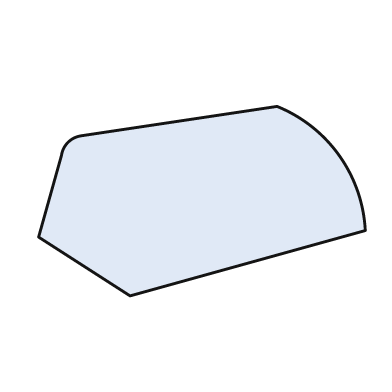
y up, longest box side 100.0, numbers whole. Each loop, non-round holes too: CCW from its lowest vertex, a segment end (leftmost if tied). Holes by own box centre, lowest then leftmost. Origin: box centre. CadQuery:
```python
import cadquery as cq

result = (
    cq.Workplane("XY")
    .moveTo(-22.0, -29.0)
    .lineTo(50.0, -9.0)
    .threePointArc((42.0, 14.0), (23.0, 29.0))
    .lineTo(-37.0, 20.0)
    .threePointArc((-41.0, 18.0), (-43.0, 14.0))
    .lineTo(-50.0, -11.0)
    .close()
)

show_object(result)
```